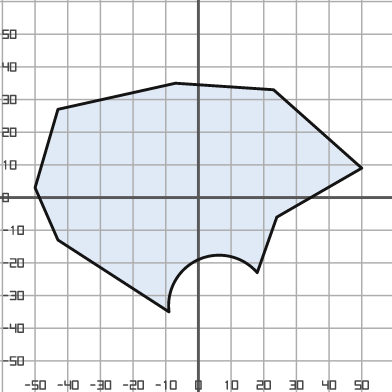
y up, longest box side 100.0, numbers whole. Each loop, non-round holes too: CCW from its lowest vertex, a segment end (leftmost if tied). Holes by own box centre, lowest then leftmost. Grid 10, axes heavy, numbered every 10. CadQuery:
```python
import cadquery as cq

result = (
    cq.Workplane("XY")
    .moveTo(-9.0, -35.0)
    .threePointArc((0.0, -19.0), (18.0, -23.0))
    .lineTo(24.0, -6.0)
    .lineTo(50.0, 9.0)
    .lineTo(23.0, 33.0)
    .lineTo(-7.0, 35.0)
    .lineTo(-43.0, 27.0)
    .lineTo(-50.0, 3.0)
    .lineTo(-43.0, -13.0)
    .close()
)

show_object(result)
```